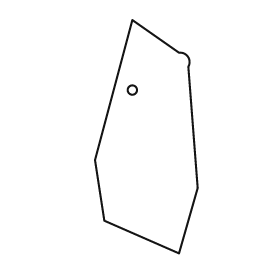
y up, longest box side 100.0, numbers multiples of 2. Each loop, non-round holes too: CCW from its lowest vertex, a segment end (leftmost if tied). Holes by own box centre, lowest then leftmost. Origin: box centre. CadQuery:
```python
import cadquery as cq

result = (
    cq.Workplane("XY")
    .moveTo(14.0, -50.0)
    .lineTo(22.0, -22.0)
    .lineTo(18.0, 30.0)
    .threePointArc((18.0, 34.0), (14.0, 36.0))
    .lineTo(-6.0, 50.0)
    .lineTo(-22.0, -10.0)
    .lineTo(-18.0, -36.0)
    .close()
    .moveTo(-6.0, 20.0)
    .circle(2.0)
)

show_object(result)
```